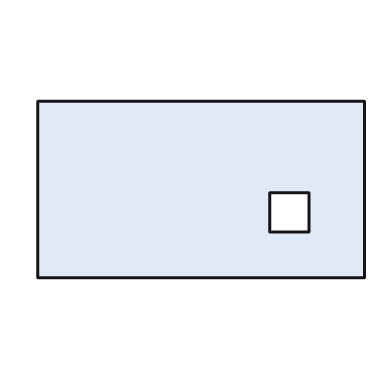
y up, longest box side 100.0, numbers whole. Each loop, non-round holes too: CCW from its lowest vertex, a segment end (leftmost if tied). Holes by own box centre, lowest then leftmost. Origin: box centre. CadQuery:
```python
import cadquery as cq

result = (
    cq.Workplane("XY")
    .moveTo(-50.0, -27.0)
    .lineTo(50.0, -27.0)
    .lineTo(50.0, 27.0)
    .lineTo(-50.0, 27.0)
    .close()
    .moveTo(21.0, -13.0)
    .lineTo(33.0, -13.0)
    .lineTo(33.0, -1.0)
    .lineTo(21.0, -1.0)
    .close()
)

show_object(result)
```